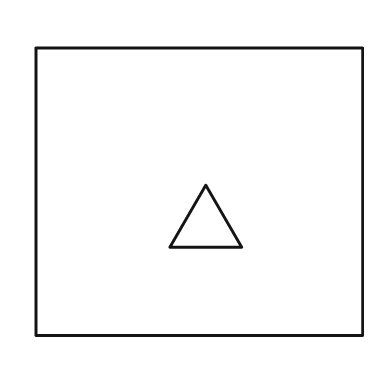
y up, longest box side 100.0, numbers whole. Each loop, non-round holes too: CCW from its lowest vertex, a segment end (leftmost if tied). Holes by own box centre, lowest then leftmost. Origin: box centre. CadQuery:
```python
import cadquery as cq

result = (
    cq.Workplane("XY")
    .moveTo(-50.0, -44.0)
    .lineTo(50.0, -44.0)
    .lineTo(50.0, 44.0)
    .lineTo(-50.0, 44.0)
    .close()
    .moveTo(-9.0, -17.0)
    .lineTo(13.0, -17.0)
    .lineTo(2.0, 2.0)
    .close()
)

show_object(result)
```